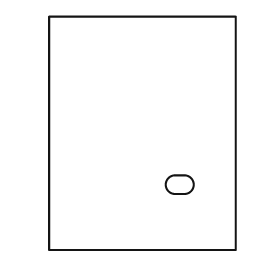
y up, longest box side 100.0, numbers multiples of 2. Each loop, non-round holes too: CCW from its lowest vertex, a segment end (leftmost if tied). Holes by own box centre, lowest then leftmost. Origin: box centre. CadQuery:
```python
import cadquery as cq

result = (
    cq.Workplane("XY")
    .moveTo(-40.0, -50.0)
    .lineTo(40.0, -50.0)
    .lineTo(40.0, 50.0)
    .lineTo(-40.0, 50.0)
    .close()
    .moveTo(14.0, -26.0)
    .lineTo(18.0, -26.0)
    .threePointArc((22.0, -22.0), (18.0, -18.0))
    .lineTo(14.0, -18.0)
    .threePointArc((10.0, -22.0), (14.0, -26.0))
    .close()
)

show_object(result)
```